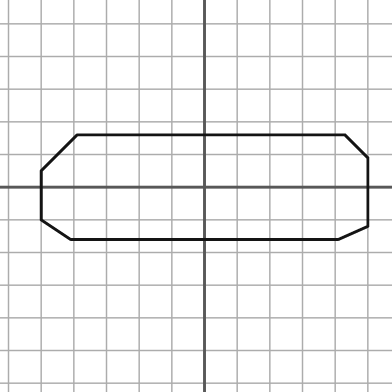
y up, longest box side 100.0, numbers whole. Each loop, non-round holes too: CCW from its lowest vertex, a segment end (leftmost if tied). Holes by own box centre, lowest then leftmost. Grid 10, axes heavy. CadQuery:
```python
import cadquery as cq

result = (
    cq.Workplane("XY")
    .moveTo(-41.0, -16.0)
    .lineTo(41.0, -16.0)
    .lineTo(50.0, -12.0)
    .lineTo(50.0, 9.0)
    .lineTo(43.0, 16.0)
    .lineTo(-39.0, 16.0)
    .lineTo(-50.0, 5.0)
    .lineTo(-50.0, -10.0)
    .close()
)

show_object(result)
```